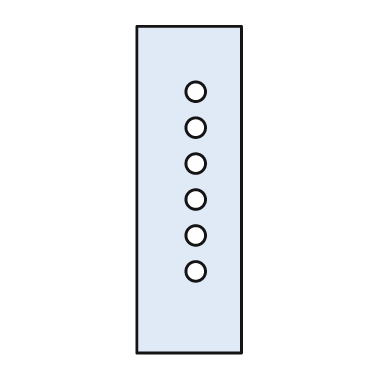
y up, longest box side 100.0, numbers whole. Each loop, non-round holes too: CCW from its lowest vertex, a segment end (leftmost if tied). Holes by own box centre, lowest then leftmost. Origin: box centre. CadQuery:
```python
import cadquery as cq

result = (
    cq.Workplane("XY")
    .moveTo(-16.0, -50.0)
    .lineTo(16.0, -50.0)
    .lineTo(16.0, 50.0)
    .lineTo(-16.0, 50.0)
    .close()
    .moveTo(2.0, -25.0)
    .circle(3.0)
    .moveTo(2.0, -14.0)
    .circle(3.0)
    .moveTo(2.0, -3.0)
    .circle(3.0)
    .moveTo(2.0, 8.0)
    .circle(3.0)
    .moveTo(2.0, 19.0)
    .circle(3.0)
    .moveTo(2.0, 30.0)
    .circle(3.0)
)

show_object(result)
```